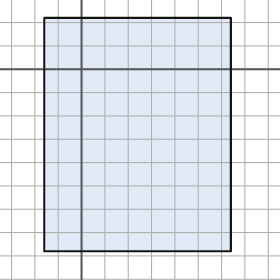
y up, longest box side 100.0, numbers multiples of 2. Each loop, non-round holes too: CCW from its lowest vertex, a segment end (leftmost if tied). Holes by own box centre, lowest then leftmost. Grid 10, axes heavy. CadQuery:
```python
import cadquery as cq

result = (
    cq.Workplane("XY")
    .moveTo(-16.0, -78.0)
    .lineTo(64.0, -78.0)
    .lineTo(64.0, 22.0)
    .lineTo(-16.0, 22.0)
    .close()
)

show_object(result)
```